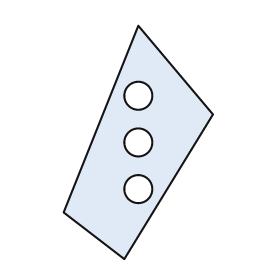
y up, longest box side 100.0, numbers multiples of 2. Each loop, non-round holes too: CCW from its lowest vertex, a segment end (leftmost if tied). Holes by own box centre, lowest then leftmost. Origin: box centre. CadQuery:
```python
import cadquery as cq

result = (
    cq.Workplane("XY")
    .moveTo(-6.0, -50.0)
    .lineTo(32.0, 12.0)
    .lineTo(0.0, 50.0)
    .lineTo(-32.0, -30.0)
    .close()
    .moveTo(0.0, -20.0)
    .circle(6.0)
    .moveTo(0.0, 0.0)
    .circle(6.0)
    .moveTo(0.0, 20.0)
    .circle(6.0)
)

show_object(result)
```